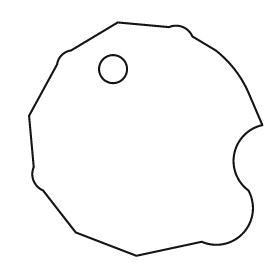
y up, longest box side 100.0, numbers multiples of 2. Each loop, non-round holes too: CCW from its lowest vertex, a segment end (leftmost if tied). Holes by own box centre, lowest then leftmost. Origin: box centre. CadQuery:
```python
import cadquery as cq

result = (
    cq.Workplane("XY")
    .moveTo(-4.0, -50.0)
    .lineTo(24.0, -44.0)
    .threePointArc((42.0, -40.0), (44.0, -22.0))
    .threePointArc((38.0, -6.0), (50.0, 6.0))
    .lineTo(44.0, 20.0)
    .threePointArc((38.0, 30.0), (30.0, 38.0))
    .lineTo(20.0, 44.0)
    .threePointArc((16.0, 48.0), (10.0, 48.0))
    .lineTo(-12.0, 50.0)
    .lineTo(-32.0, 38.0)
    .threePointArc((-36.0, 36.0), (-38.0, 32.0))
    .lineTo(-50.0, 10.0)
    .lineTo(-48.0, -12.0)
    .threePointArc((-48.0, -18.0), (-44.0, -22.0))
    .lineTo(-30.0, -40.0)
    .close()
    .moveTo(-14.0, 30.0)
    .circle(6.0)
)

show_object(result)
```